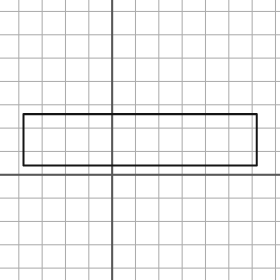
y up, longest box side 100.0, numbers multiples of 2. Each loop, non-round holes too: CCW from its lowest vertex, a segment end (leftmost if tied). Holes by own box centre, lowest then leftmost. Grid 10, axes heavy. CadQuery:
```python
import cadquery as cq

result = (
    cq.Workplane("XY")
    .moveTo(-38.0, 4.0)
    .lineTo(62.0, 4.0)
    .lineTo(62.0, 26.0)
    .lineTo(-38.0, 26.0)
    .close()
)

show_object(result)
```